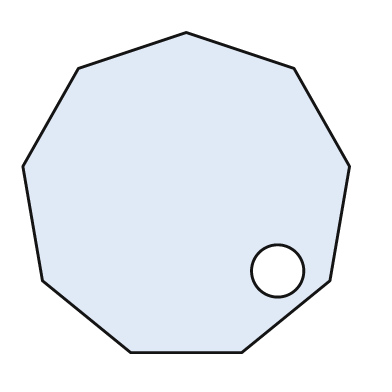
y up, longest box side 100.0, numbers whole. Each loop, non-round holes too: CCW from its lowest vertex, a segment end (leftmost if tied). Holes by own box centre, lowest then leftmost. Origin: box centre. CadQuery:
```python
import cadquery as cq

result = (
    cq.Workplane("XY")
    .moveTo(-17.0, -49.0)
    .lineTo(17.0, -49.0)
    .lineTo(44.0, -27.0)
    .lineTo(50.0, 8.0)
    .lineTo(33.0, 38.0)
    .lineTo(0.0, 49.0)
    .lineTo(-33.0, 38.0)
    .lineTo(-50.0, 8.0)
    .lineTo(-44.0, -27.0)
    .close()
    .moveTo(28.0, -24.0)
    .circle(8.0)
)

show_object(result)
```